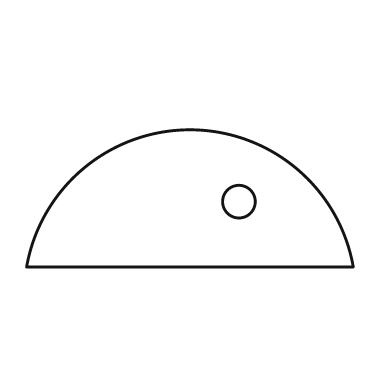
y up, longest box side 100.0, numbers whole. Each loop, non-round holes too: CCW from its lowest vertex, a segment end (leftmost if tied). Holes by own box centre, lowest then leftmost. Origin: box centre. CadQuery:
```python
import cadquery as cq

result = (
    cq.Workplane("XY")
    .moveTo(-50.0, -21.0)
    .lineTo(50.0, -21.0)
    .threePointArc((0.0, 21.0), (-50.0, -21.0))
    .close()
    .moveTo(15.0, -1.0)
    .circle(5.0)
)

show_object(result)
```